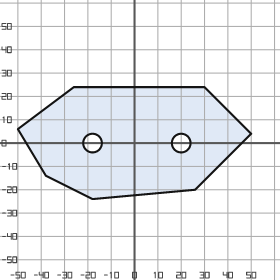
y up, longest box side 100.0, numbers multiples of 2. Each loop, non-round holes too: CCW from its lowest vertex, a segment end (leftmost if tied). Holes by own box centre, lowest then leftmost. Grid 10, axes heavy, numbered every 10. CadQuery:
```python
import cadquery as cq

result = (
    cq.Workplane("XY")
    .moveTo(-18.0, -24.0)
    .lineTo(26.0, -20.0)
    .lineTo(50.0, 4.0)
    .lineTo(30.0, 24.0)
    .lineTo(-26.0, 24.0)
    .lineTo(-50.0, 6.0)
    .lineTo(-38.0, -14.0)
    .close()
    .moveTo(-18.0, 0.0)
    .circle(4.0)
    .moveTo(20.0, 0.0)
    .circle(4.0)
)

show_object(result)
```